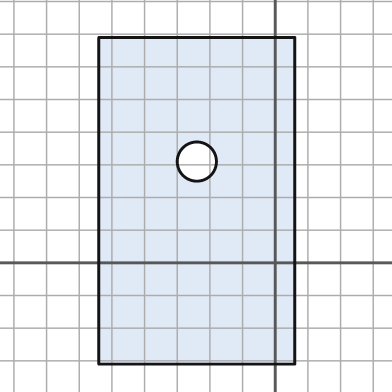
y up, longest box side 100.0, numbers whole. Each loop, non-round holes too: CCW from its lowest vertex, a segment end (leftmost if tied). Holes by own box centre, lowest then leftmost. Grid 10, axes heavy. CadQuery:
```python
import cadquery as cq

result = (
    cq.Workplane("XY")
    .moveTo(-54.0, -31.0)
    .lineTo(6.0, -31.0)
    .lineTo(6.0, 69.0)
    .lineTo(-54.0, 69.0)
    .close()
    .moveTo(-24.0, 31.0)
    .circle(6.0)
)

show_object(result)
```